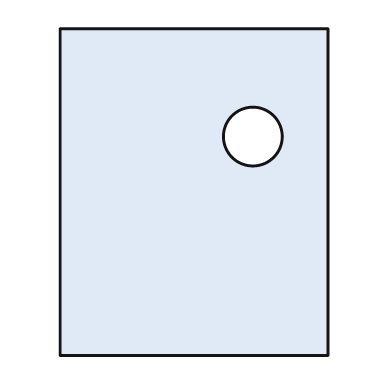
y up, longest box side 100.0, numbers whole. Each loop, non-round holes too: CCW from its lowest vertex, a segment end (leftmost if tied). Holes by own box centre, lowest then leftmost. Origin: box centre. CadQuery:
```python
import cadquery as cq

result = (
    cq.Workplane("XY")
    .moveTo(-41.0, -50.0)
    .lineTo(41.0, -50.0)
    .lineTo(41.0, 50.0)
    .lineTo(-41.0, 50.0)
    .close()
    .moveTo(18.0, 17.0)
    .circle(9.0)
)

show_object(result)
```